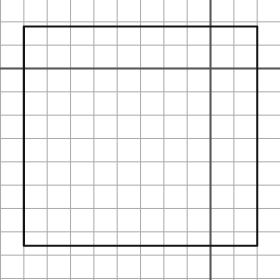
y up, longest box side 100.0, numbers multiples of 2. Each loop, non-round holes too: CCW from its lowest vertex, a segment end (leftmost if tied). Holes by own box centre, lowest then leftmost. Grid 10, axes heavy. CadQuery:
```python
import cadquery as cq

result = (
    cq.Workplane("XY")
    .moveTo(-80.0, -76.0)
    .lineTo(20.0, -76.0)
    .lineTo(20.0, 18.0)
    .lineTo(-80.0, 18.0)
    .close()
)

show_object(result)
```